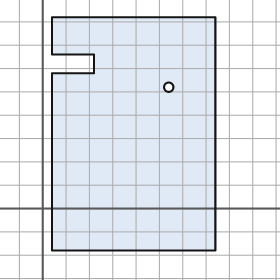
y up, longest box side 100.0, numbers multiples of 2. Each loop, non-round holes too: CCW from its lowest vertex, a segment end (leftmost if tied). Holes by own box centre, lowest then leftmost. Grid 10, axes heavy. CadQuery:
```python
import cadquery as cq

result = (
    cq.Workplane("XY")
    .moveTo(4.0, -18.0)
    .lineTo(74.0, -18.0)
    .lineTo(74.0, 82.0)
    .lineTo(4.0, 82.0)
    .lineTo(4.0, 66.0)
    .lineTo(22.0, 66.0)
    .lineTo(22.0, 58.0)
    .lineTo(4.0, 58.0)
    .close()
    .moveTo(54.0, 52.0)
    .circle(2.0)
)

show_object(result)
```